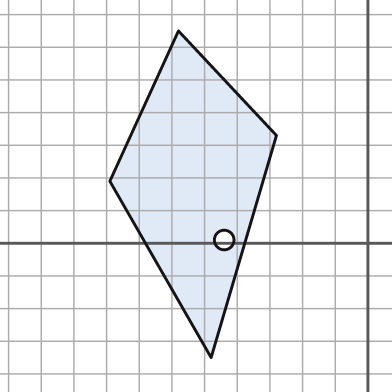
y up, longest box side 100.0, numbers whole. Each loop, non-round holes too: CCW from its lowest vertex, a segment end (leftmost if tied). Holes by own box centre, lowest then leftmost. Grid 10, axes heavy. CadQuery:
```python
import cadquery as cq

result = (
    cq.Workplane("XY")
    .moveTo(-48.0, -35.0)
    .lineTo(-28.0, 33.0)
    .lineTo(-58.0, 65.0)
    .lineTo(-79.0, 19.0)
    .close()
    .moveTo(-44.0, 1.0)
    .circle(3.0)
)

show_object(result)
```